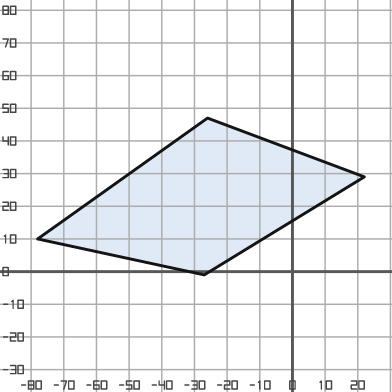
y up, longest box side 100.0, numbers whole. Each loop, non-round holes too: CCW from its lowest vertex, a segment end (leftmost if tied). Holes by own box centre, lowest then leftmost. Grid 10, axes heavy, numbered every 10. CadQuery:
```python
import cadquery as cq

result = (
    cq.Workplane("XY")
    .moveTo(-27.0, -1.0)
    .lineTo(22.0, 29.0)
    .lineTo(-26.0, 47.0)
    .lineTo(-78.0, 10.0)
    .close()
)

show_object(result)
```